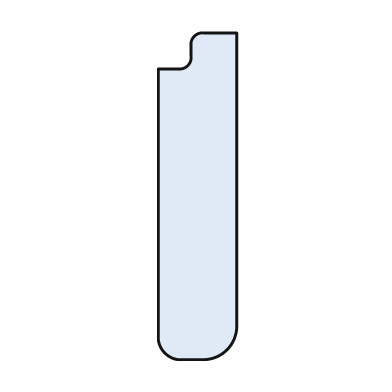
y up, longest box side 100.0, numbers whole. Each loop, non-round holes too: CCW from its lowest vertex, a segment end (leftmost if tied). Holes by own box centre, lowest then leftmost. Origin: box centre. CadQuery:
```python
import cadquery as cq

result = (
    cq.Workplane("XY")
    .moveTo(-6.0, -50.0)
    .lineTo(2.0, -50.0)
    .threePointArc((9.0, -47.0), (12.0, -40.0))
    .lineTo(12.0, 50.0)
    .lineTo(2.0, 50.0)
    .threePointArc((-1.0, 49.0), (-2.0, 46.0))
    .lineTo(-2.0, 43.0)
    .threePointArc((-3.0, 40.0), (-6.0, 39.0))
    .lineTo(-12.0, 39.0)
    .lineTo(-12.0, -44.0)
    .threePointArc((-10.0, -48.0), (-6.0, -50.0))
    .close()
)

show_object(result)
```